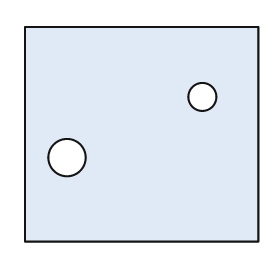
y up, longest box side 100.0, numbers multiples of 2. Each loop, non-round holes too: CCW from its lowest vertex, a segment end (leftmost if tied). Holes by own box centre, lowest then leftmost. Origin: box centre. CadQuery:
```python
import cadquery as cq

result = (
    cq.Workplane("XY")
    .moveTo(-50.0, -46.0)
    .lineTo(50.0, -46.0)
    .lineTo(50.0, 46.0)
    .lineTo(-50.0, 46.0)
    .close()
    .moveTo(-32.0, -10.0)
    .circle(8.0)
    .moveTo(26.0, 16.0)
    .circle(6.0)
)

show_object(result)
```